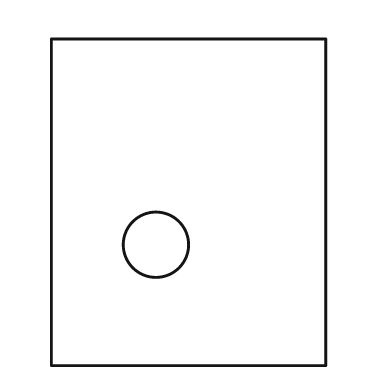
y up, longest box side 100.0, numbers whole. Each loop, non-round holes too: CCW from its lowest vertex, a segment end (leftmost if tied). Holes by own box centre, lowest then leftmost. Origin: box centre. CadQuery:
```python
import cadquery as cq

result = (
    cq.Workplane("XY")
    .moveTo(-42.0, -50.0)
    .lineTo(42.0, -50.0)
    .lineTo(42.0, 50.0)
    .lineTo(-42.0, 50.0)
    .close()
    .moveTo(-10.0, -13.0)
    .circle(10.0)
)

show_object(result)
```